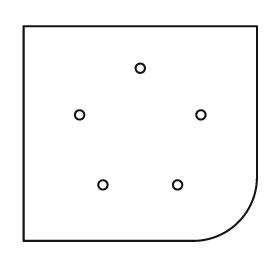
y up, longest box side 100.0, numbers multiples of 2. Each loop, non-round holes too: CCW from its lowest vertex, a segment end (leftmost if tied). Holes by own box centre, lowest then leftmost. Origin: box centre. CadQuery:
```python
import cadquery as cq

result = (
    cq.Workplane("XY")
    .moveTo(-50.0, -46.0)
    .lineTo(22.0, -46.0)
    .threePointArc((42.0, -38.0), (50.0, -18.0))
    .lineTo(50.0, 46.0)
    .lineTo(-50.0, 46.0)
    .close()
    .moveTo(-16.0, -22.0)
    .circle(2.0)
    .moveTo(16.0, -22.0)
    .circle(2.0)
    .moveTo(-26.0, 8.0)
    .circle(2.0)
    .moveTo(26.0, 8.0)
    .circle(2.0)
    .moveTo(0.0, 28.0)
    .circle(2.0)
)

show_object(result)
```